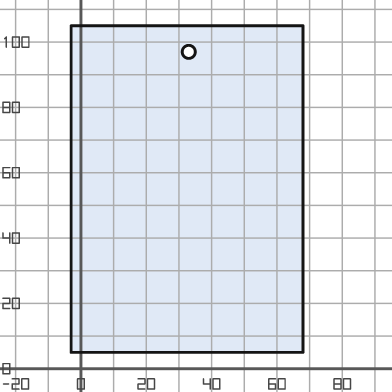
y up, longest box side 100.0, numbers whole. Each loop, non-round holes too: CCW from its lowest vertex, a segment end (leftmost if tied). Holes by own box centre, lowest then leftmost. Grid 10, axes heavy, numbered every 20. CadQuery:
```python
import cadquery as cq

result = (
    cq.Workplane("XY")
    .moveTo(-3.0, 5.0)
    .lineTo(68.0, 5.0)
    .lineTo(68.0, 105.0)
    .lineTo(-3.0, 105.0)
    .close()
    .moveTo(33.0, 97.0)
    .circle(2.0)
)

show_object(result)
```